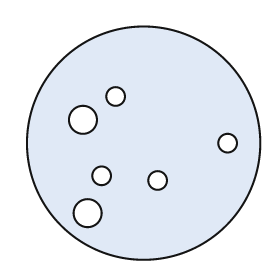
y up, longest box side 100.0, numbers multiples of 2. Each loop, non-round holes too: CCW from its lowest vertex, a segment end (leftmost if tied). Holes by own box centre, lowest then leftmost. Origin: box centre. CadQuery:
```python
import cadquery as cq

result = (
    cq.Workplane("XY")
    .moveTo(0.0, 0.0)
    .circle(50.0)
    .moveTo(-24.0, -30.0)
    .circle(6.0)
    .moveTo(6.0, -16.0)
    .circle(4.0)
    .moveTo(-18.0, -14.0)
    .circle(4.0)
    .moveTo(36.0, 0.0)
    .circle(4.0)
    .moveTo(-26.0, 10.0)
    .circle(6.0)
    .moveTo(-12.0, 20.0)
    .circle(4.0)
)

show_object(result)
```